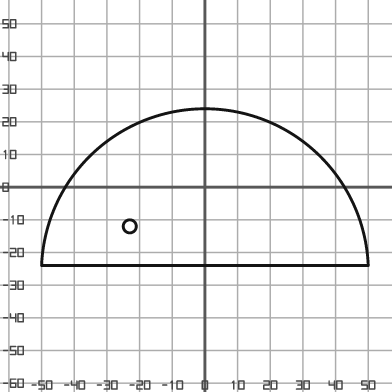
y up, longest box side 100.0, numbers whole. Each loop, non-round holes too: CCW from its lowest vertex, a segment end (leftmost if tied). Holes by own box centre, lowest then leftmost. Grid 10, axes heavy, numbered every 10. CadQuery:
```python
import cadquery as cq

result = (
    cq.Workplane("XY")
    .moveTo(-50.0, -24.0)
    .lineTo(50.0, -24.0)
    .threePointArc((0.0, 24.0), (-50.0, -24.0))
    .close()
    .moveTo(-23.0, -12.0)
    .circle(2.0)
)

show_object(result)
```